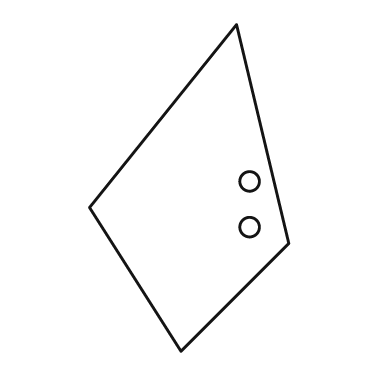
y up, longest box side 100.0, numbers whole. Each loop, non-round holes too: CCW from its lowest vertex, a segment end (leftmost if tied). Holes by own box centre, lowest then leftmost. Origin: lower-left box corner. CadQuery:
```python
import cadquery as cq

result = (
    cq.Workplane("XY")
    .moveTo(28.0, 0.0)
    .lineTo(61.0, 33.0)
    .lineTo(45.0, 100.0)
    .lineTo(0.0, 44.0)
    .close()
    .moveTo(49.0, 38.0)
    .circle(3.0)
    .moveTo(49.0, 52.0)
    .circle(3.0)
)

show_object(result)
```